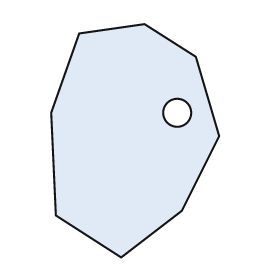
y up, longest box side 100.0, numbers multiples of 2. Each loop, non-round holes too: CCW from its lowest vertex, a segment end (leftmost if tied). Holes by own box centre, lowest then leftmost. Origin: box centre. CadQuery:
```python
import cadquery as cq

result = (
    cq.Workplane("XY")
    .moveTo(-6.0, -50.0)
    .lineTo(20.0, -30.0)
    .lineTo(36.0, 2.0)
    .lineTo(26.0, 36.0)
    .lineTo(4.0, 50.0)
    .lineTo(-24.0, 46.0)
    .lineTo(-36.0, 12.0)
    .lineTo(-34.0, -32.0)
    .close()
    .moveTo(18.0, 12.0)
    .circle(6.0)
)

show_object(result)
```